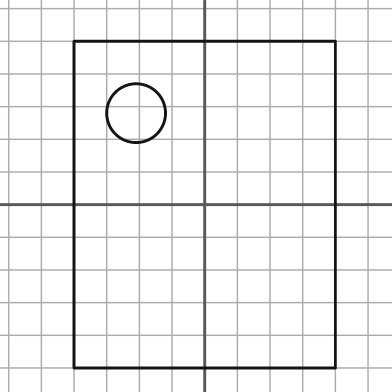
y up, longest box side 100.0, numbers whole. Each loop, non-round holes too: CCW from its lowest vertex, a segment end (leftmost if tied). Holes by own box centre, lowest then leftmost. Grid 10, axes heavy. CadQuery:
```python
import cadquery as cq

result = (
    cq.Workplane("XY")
    .moveTo(-40.0, -50.0)
    .lineTo(40.0, -50.0)
    .lineTo(40.0, 50.0)
    .lineTo(-40.0, 50.0)
    .close()
    .moveTo(-21.0, 28.0)
    .circle(9.0)
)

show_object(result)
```